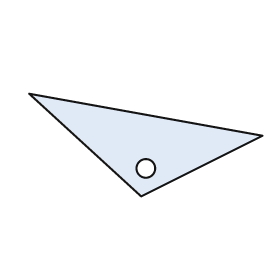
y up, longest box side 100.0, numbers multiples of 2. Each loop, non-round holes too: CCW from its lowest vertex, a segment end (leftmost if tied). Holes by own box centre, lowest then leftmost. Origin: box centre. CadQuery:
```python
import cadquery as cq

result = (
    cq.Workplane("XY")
    .moveTo(-2.0, -22.0)
    .lineTo(50.0, 4.0)
    .lineTo(-50.0, 22.0)
    .close()
    .moveTo(0.0, -10.0)
    .circle(4.0)
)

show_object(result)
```